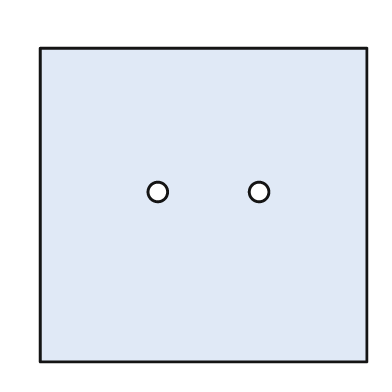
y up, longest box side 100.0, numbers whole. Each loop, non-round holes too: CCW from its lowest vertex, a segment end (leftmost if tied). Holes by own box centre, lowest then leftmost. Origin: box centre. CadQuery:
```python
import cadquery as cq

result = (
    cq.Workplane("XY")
    .moveTo(-50.0, -48.0)
    .lineTo(50.0, -48.0)
    .lineTo(50.0, 48.0)
    .lineTo(-50.0, 48.0)
    .close()
    .moveTo(-14.0, 4.0)
    .circle(3.0)
    .moveTo(17.0, 4.0)
    .circle(3.0)
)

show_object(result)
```